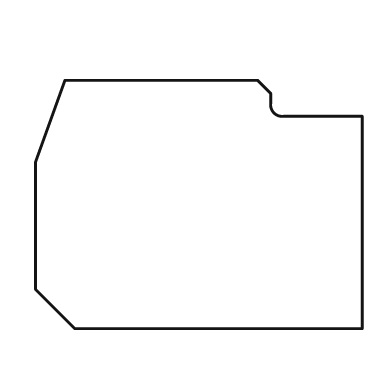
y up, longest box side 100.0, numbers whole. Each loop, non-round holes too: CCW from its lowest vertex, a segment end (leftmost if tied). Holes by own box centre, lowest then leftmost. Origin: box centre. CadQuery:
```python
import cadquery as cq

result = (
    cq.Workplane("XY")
    .moveTo(-38.0, -38.0)
    .lineTo(50.0, -38.0)
    .lineTo(50.0, 27.0)
    .lineTo(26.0, 27.0)
    .threePointArc((23.0, 28.0), (22.0, 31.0))
    .lineTo(22.0, 34.0)
    .lineTo(18.0, 38.0)
    .lineTo(-41.0, 38.0)
    .lineTo(-50.0, 13.0)
    .lineTo(-50.0, -26.0)
    .close()
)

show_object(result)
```